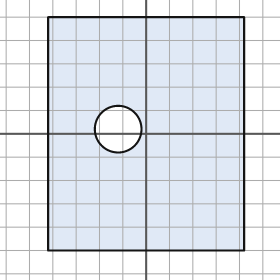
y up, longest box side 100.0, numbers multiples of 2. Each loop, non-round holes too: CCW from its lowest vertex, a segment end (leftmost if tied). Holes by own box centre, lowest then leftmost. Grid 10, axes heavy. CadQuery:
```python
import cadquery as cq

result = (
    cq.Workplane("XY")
    .moveTo(-42.0, -50.0)
    .lineTo(42.0, -50.0)
    .lineTo(42.0, 50.0)
    .lineTo(-42.0, 50.0)
    .close()
    .moveTo(-12.0, 2.0)
    .circle(10.0)
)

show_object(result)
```